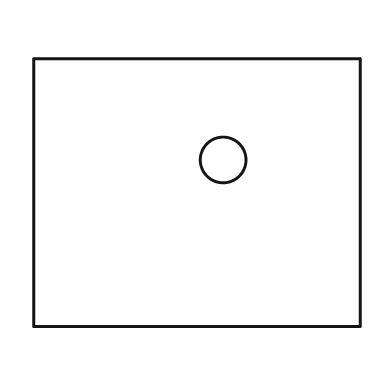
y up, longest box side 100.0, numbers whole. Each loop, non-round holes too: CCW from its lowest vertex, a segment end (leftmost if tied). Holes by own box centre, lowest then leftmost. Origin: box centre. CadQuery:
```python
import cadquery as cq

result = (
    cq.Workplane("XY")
    .moveTo(-50.0, -41.0)
    .lineTo(50.0, -41.0)
    .lineTo(50.0, 41.0)
    .lineTo(-50.0, 41.0)
    .close()
    .moveTo(8.0, 10.0)
    .circle(7.0)
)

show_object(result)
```